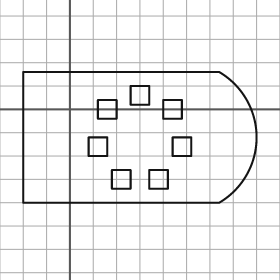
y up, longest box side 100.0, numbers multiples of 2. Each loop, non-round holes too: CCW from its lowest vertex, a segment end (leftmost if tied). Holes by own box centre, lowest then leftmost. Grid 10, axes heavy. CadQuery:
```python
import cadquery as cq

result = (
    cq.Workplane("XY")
    .moveTo(-20.0, -40.0)
    .lineTo(64.0, -40.0)
    .threePointArc((80.0, -12.0), (64.0, 16.0))
    .lineTo(-20.0, 16.0)
    .close()
    .moveTo(18.0, -34.0)
    .lineTo(26.0, -34.0)
    .lineTo(26.0, -26.0)
    .lineTo(18.0, -26.0)
    .close()
    .moveTo(34.0, -34.0)
    .lineTo(42.0, -34.0)
    .lineTo(42.0, -26.0)
    .lineTo(34.0, -26.0)
    .close()
    .moveTo(8.0, -20.0)
    .lineTo(16.0, -20.0)
    .lineTo(16.0, -12.0)
    .lineTo(8.0, -12.0)
    .close()
    .moveTo(44.0, -20.0)
    .lineTo(52.0, -20.0)
    .lineTo(52.0, -12.0)
    .lineTo(44.0, -12.0)
    .close()
    .moveTo(12.0, -4.0)
    .lineTo(20.0, -4.0)
    .lineTo(20.0, 4.0)
    .lineTo(12.0, 4.0)
    .close()
    .moveTo(40.0, -4.0)
    .lineTo(48.0, -4.0)
    .lineTo(48.0, 4.0)
    .lineTo(40.0, 4.0)
    .close()
    .moveTo(26.0, 2.0)
    .lineTo(34.0, 2.0)
    .lineTo(34.0, 10.0)
    .lineTo(26.0, 10.0)
    .close()
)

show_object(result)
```